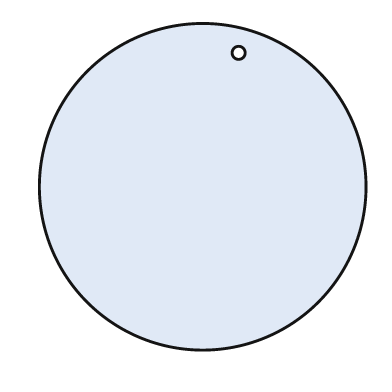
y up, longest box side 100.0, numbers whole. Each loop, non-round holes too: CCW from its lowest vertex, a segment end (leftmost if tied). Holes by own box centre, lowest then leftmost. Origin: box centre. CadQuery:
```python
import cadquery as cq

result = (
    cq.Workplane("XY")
    .moveTo(0.0, 0.0)
    .circle(50.0)
    .moveTo(11.0, 41.0)
    .circle(2.0)
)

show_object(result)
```